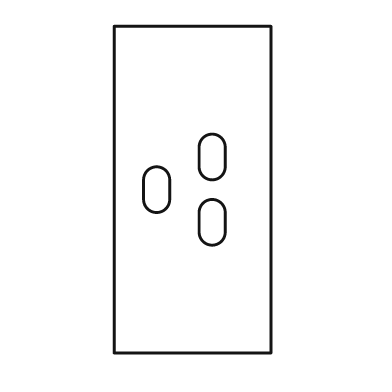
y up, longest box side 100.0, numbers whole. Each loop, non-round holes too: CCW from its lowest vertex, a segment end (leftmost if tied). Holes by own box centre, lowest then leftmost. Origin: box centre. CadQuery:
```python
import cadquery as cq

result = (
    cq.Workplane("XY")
    .moveTo(-24.0, -50.0)
    .lineTo(24.0, -50.0)
    .lineTo(24.0, 50.0)
    .lineTo(-24.0, 50.0)
    .close()
    .moveTo(2.0, -13.0)
    .threePointArc((6.0, -17.0), (10.0, -13.0))
    .lineTo(10.0, -7.0)
    .threePointArc((6.0, -3.0), (2.0, -7.0))
    .close()
    .moveTo(-15.0, -3.0)
    .threePointArc((-11.0, -7.0), (-7.0, -3.0))
    .lineTo(-7.0, 3.0)
    .threePointArc((-11.0, 7.0), (-15.0, 3.0))
    .close()
    .moveTo(2.0, 7.0)
    .threePointArc((6.0, 3.0), (10.0, 7.0))
    .lineTo(10.0, 13.0)
    .threePointArc((6.0, 17.0), (2.0, 13.0))
    .close()
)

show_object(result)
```